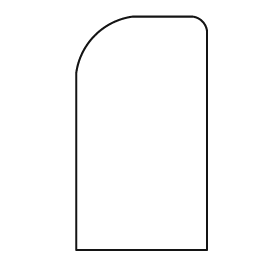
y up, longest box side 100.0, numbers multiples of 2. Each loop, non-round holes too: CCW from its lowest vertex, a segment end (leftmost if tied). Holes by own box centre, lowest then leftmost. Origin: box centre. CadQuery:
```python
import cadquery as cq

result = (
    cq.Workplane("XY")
    .moveTo(-28.0, -50.0)
    .lineTo(28.0, -50.0)
    .lineTo(28.0, 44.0)
    .threePointArc((26.0, 48.0), (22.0, 50.0))
    .lineTo(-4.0, 50.0)
    .threePointArc((-20.0, 42.0), (-28.0, 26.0))
    .close()
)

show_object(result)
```